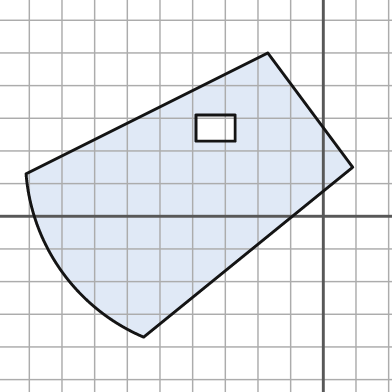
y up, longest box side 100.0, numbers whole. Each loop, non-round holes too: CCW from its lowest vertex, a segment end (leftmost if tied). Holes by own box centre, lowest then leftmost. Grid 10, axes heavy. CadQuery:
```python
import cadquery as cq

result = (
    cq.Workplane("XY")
    .moveTo(-55.0, -37.0)
    .lineTo(9.0, 15.0)
    .lineTo(-17.0, 50.0)
    .lineTo(-91.0, 13.0)
    .threePointArc((-80.0, -17.0), (-55.0, -37.0))
    .close()
    .moveTo(-39.0, 23.0)
    .lineTo(-27.0, 23.0)
    .lineTo(-27.0, 31.0)
    .lineTo(-39.0, 31.0)
    .close()
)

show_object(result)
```